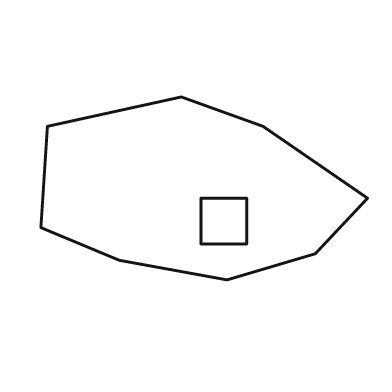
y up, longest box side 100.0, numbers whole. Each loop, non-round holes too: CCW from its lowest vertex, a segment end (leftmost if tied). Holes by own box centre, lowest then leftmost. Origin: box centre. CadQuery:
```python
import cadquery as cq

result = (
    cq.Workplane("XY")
    .moveTo(7.0, -28.0)
    .lineTo(34.0, -20.0)
    .lineTo(50.0, -3.0)
    .lineTo(18.0, 19.0)
    .lineTo(-7.0, 28.0)
    .lineTo(-48.0, 19.0)
    .lineTo(-50.0, -12.0)
    .lineTo(-26.0, -22.0)
    .close()
    .moveTo(-1.0, -17.0)
    .lineTo(13.0, -17.0)
    .lineTo(13.0, -3.0)
    .lineTo(-1.0, -3.0)
    .close()
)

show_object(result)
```